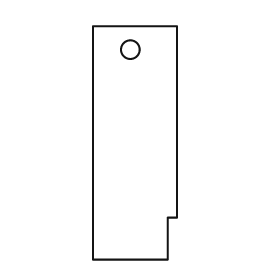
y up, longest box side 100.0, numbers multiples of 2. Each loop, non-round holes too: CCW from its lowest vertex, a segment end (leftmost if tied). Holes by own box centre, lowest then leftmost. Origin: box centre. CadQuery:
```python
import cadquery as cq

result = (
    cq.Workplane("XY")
    .moveTo(-18.0, -50.0)
    .lineTo(14.0, -50.0)
    .lineTo(14.0, -32.0)
    .lineTo(18.0, -32.0)
    .lineTo(18.0, 50.0)
    .lineTo(-18.0, 50.0)
    .close()
    .moveTo(-2.0, 40.0)
    .circle(4.0)
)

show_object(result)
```